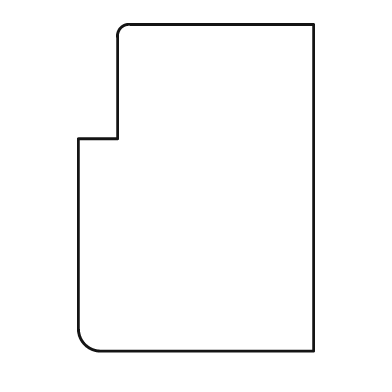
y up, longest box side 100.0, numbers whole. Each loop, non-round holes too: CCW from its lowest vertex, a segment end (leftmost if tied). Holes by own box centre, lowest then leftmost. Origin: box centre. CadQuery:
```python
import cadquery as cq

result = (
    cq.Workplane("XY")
    .moveTo(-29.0, -50.0)
    .lineTo(36.0, -50.0)
    .lineTo(36.0, 50.0)
    .lineTo(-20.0, 50.0)
    .threePointArc((-23.0, 49.0), (-24.0, 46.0))
    .lineTo(-24.0, 15.0)
    .lineTo(-36.0, 15.0)
    .lineTo(-36.0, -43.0)
    .threePointArc((-34.0, -48.0), (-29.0, -50.0))
    .close()
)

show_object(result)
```